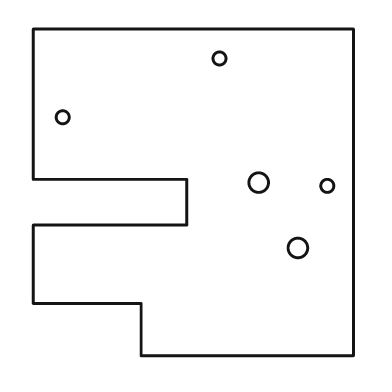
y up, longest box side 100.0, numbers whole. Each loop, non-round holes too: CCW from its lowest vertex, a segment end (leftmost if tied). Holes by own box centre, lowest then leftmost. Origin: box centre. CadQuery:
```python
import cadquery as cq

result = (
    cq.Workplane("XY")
    .moveTo(-16.0, -50.0)
    .lineTo(49.0, -50.0)
    .lineTo(49.0, 50.0)
    .lineTo(-49.0, 50.0)
    .lineTo(-49.0, 4.0)
    .lineTo(-2.0, 4.0)
    .lineTo(-2.0, -10.0)
    .lineTo(-49.0, -10.0)
    .lineTo(-49.0, -34.0)
    .lineTo(-16.0, -34.0)
    .close()
    .moveTo(32.0, -17.0)
    .circle(3.0)
    .moveTo(41.0, 2.0)
    .circle(2.0)
    .moveTo(20.0, 3.0)
    .circle(3.0)
    .moveTo(-40.0, 23.0)
    .circle(2.0)
    .moveTo(8.0, 41.0)
    .circle(2.0)
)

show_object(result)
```